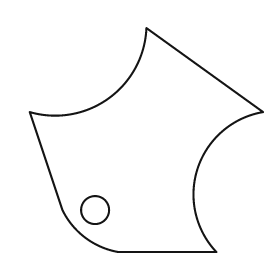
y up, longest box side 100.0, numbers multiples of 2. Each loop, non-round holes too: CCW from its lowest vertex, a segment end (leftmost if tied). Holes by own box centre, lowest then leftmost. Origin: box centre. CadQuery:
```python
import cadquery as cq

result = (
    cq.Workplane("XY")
    .moveTo(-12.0, -48.0)
    .lineTo(30.0, -48.0)
    .threePointArc((22.0, -12.0), (50.0, 12.0))
    .lineTo(0.0, 48.0)
    .threePointArc((-16.0, 18.0), (-50.0, 12.0))
    .lineTo(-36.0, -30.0)
    .threePointArc((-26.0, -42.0), (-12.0, -48.0))
    .close()
    .moveTo(-22.0, -30.0)
    .circle(6.0)
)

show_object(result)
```